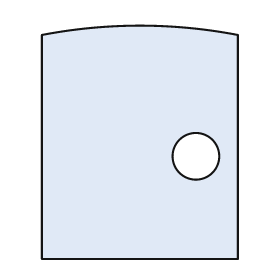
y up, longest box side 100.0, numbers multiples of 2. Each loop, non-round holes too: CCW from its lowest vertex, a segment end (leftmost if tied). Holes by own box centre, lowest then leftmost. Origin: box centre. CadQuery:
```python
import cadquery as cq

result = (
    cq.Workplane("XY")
    .moveTo(-42.0, -50.0)
    .lineTo(42.0, -50.0)
    .lineTo(42.0, 46.0)
    .threePointArc((0.0, 50.0), (-42.0, 46.0))
    .close()
    .moveTo(24.0, -6.0)
    .circle(10.0)
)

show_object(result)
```